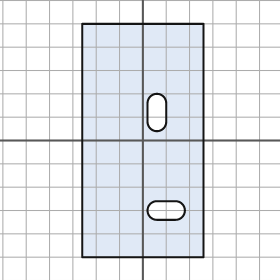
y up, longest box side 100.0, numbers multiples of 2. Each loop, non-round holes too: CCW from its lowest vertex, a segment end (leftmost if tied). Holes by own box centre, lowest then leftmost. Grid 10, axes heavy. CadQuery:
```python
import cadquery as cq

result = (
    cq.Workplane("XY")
    .moveTo(-26.0, -50.0)
    .lineTo(26.0, -50.0)
    .lineTo(26.0, 50.0)
    .lineTo(-26.0, 50.0)
    .close()
    .moveTo(6.0, -34.0)
    .lineTo(14.0, -34.0)
    .threePointArc((18.0, -30.0), (14.0, -26.0))
    .lineTo(6.0, -26.0)
    .threePointArc((2.0, -30.0), (6.0, -34.0))
    .close()
    .moveTo(2.0, 8.0)
    .threePointArc((6.0, 4.0), (10.0, 8.0))
    .lineTo(10.0, 16.0)
    .threePointArc((6.0, 20.0), (2.0, 16.0))
    .close()
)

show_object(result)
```